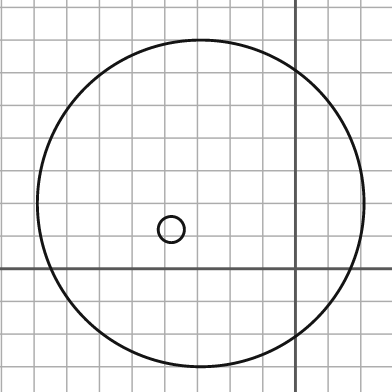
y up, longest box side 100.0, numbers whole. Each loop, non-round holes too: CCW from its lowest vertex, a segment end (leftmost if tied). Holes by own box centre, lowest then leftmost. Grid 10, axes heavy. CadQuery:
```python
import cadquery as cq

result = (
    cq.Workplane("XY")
    .moveTo(-29.0, 20.0)
    .circle(50.0)
    .moveTo(-38.0, 12.0)
    .circle(4.0)
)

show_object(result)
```